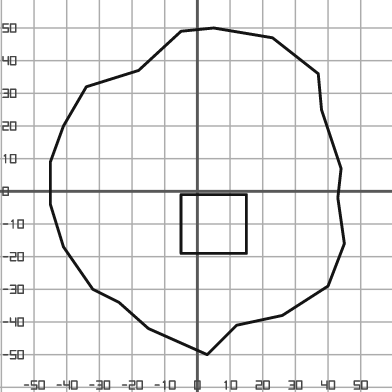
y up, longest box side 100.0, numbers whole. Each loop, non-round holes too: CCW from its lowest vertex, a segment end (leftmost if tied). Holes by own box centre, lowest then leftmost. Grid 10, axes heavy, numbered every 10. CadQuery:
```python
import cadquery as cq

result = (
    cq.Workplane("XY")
    .moveTo(3.0, -50.0)
    .lineTo(12.0, -41.0)
    .lineTo(26.0, -38.0)
    .lineTo(40.0, -29.0)
    .lineTo(45.0, -16.0)
    .lineTo(43.0, -2.0)
    .lineTo(44.0, 7.0)
    .lineTo(38.0, 25.0)
    .lineTo(37.0, 36.0)
    .lineTo(23.0, 47.0)
    .lineTo(5.0, 50.0)
    .lineTo(-5.0, 49.0)
    .lineTo(-18.0, 37.0)
    .lineTo(-34.0, 32.0)
    .lineTo(-41.0, 20.0)
    .lineTo(-45.0, 9.0)
    .lineTo(-45.0, -4.0)
    .lineTo(-41.0, -17.0)
    .lineTo(-32.0, -30.0)
    .lineTo(-24.0, -34.0)
    .lineTo(-15.0, -42.0)
    .close()
    .moveTo(-5.0, -19.0)
    .lineTo(15.0, -19.0)
    .lineTo(15.0, -1.0)
    .lineTo(-5.0, -1.0)
    .close()
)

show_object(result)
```